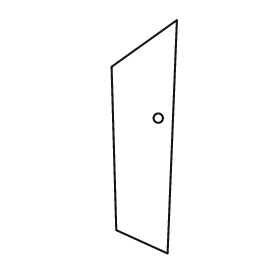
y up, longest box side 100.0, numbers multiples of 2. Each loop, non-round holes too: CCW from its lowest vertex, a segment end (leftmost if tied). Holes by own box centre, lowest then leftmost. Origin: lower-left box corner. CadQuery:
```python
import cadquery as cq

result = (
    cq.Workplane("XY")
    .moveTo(24.0, 0.0)
    .lineTo(28.0, 100.0)
    .lineTo(0.0, 80.0)
    .lineTo(2.0, 10.0)
    .close()
    .moveTo(20.0, 58.0)
    .circle(2.0)
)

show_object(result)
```